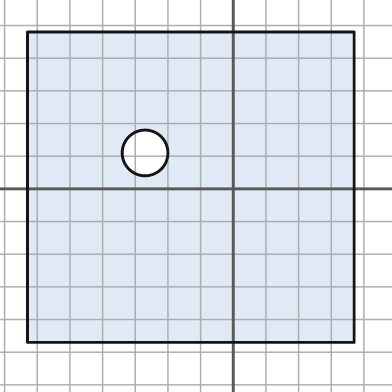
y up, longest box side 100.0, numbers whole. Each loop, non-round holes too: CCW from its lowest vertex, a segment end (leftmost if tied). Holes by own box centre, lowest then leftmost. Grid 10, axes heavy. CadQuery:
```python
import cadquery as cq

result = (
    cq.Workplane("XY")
    .moveTo(-63.0, -47.0)
    .lineTo(37.0, -47.0)
    .lineTo(37.0, 48.0)
    .lineTo(-63.0, 48.0)
    .close()
    .moveTo(-27.0, 11.0)
    .circle(7.0)
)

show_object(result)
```